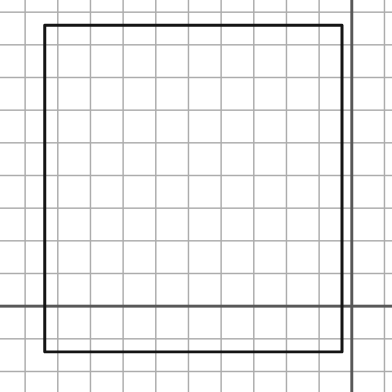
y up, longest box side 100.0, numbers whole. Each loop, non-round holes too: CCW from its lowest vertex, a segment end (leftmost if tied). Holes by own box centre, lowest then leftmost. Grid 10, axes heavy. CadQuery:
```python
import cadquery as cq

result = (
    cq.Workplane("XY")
    .moveTo(-94.0, -14.0)
    .lineTo(-3.0, -14.0)
    .lineTo(-3.0, 86.0)
    .lineTo(-94.0, 86.0)
    .close()
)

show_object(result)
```